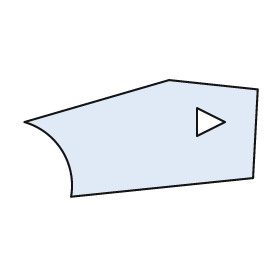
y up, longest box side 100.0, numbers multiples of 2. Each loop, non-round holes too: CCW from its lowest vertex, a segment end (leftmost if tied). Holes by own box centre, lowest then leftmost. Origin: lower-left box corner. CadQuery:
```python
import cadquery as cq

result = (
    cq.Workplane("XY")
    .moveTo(20.0, 0.0)
    .lineTo(98.0, 8.0)
    .lineTo(100.0, 46.0)
    .lineTo(62.0, 50.0)
    .lineTo(0.0, 32.0)
    .threePointArc((16.0, 20.0), (20.0, 0.0))
    .close()
    .moveTo(74.0, 26.0)
    .lineTo(86.0, 32.0)
    .lineTo(74.0, 38.0)
    .close()
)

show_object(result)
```